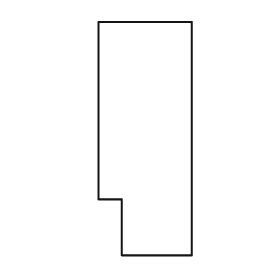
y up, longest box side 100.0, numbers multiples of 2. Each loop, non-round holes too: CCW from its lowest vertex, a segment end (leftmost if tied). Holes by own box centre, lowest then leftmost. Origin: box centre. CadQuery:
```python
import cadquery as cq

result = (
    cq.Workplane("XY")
    .moveTo(-10.0, -50.0)
    .lineTo(20.0, -50.0)
    .lineTo(20.0, 50.0)
    .lineTo(-20.0, 50.0)
    .lineTo(-20.0, -26.0)
    .lineTo(-10.0, -26.0)
    .close()
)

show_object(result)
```